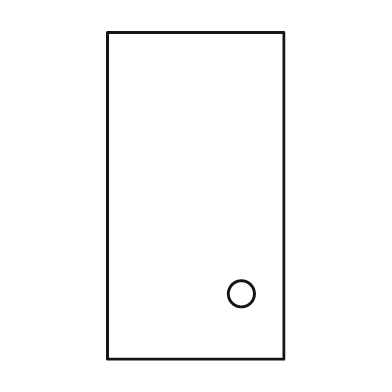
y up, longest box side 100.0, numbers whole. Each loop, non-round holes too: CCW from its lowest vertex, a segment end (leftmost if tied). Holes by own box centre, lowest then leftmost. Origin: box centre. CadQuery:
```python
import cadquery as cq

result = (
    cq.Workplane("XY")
    .moveTo(-27.0, -50.0)
    .lineTo(27.0, -50.0)
    .lineTo(27.0, 50.0)
    .lineTo(-27.0, 50.0)
    .close()
    .moveTo(14.0, -30.0)
    .circle(4.0)
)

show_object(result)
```